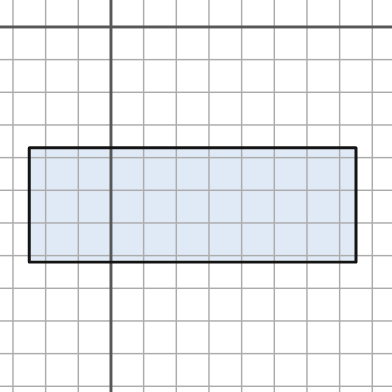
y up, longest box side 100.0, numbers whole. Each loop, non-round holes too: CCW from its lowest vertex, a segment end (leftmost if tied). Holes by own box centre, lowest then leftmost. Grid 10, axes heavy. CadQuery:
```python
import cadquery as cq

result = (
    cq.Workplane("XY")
    .moveTo(-25.0, -72.0)
    .lineTo(75.0, -72.0)
    .lineTo(75.0, -37.0)
    .lineTo(-25.0, -37.0)
    .close()
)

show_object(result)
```